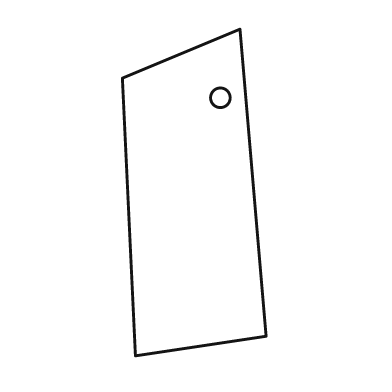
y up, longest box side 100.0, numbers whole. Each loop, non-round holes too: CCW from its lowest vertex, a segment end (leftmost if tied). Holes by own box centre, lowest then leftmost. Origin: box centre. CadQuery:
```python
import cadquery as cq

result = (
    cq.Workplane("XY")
    .moveTo(-18.0, -50.0)
    .lineTo(22.0, -44.0)
    .lineTo(14.0, 50.0)
    .lineTo(-22.0, 35.0)
    .close()
    .moveTo(8.0, 29.0)
    .circle(3.0)
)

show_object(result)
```